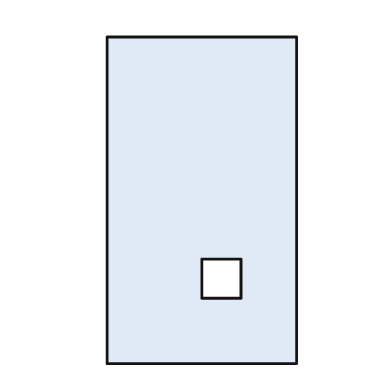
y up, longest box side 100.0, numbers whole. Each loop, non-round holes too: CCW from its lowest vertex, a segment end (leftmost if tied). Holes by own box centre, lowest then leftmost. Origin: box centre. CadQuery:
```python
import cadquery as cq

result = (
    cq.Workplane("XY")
    .moveTo(-29.0, -50.0)
    .lineTo(29.0, -50.0)
    .lineTo(29.0, 50.0)
    .lineTo(-29.0, 50.0)
    .close()
    .moveTo(0.0, -30.0)
    .lineTo(12.0, -30.0)
    .lineTo(12.0, -18.0)
    .lineTo(0.0, -18.0)
    .close()
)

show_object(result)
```